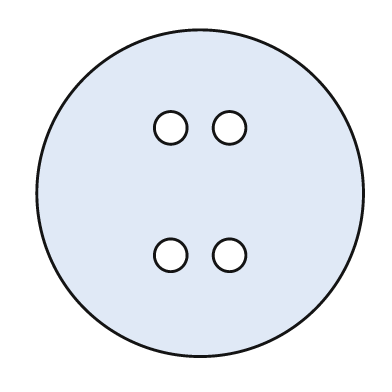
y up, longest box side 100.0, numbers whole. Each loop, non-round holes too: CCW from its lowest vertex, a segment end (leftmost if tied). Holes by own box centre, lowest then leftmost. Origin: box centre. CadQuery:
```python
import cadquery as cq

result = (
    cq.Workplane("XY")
    .moveTo(0.0, 0.0)
    .circle(50.0)
    .moveTo(-9.0, -19.0)
    .circle(5.0)
    .moveTo(9.0, -19.0)
    .circle(5.0)
    .moveTo(-9.0, 20.0)
    .circle(5.0)
    .moveTo(9.0, 20.0)
    .circle(5.0)
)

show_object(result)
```